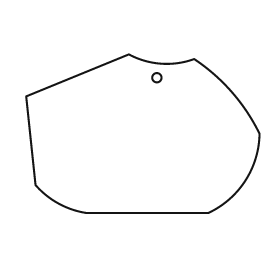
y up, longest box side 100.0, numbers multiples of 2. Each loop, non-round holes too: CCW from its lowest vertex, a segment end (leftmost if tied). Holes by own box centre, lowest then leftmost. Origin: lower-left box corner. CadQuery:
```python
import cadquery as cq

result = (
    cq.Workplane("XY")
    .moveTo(26.0, 0.0)
    .lineTo(78.0, 0.0)
    .threePointArc((94.0, 14.0), (100.0, 34.0))
    .threePointArc((88.0, 52.0), (72.0, 66.0))
    .threePointArc((58.0, 64.0), (44.0, 68.0))
    .lineTo(0.0, 50.0)
    .lineTo(4.0, 12.0)
    .threePointArc((14.0, 4.0), (26.0, 0.0))
    .close()
    .moveTo(56.0, 58.0)
    .circle(2.0)
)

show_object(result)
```